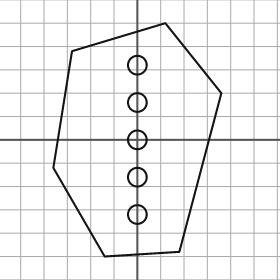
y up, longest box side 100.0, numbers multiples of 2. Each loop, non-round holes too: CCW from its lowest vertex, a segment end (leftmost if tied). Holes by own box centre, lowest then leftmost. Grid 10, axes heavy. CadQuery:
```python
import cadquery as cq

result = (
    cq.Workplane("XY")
    .moveTo(-14.0, -50.0)
    .lineTo(18.0, -48.0)
    .lineTo(36.0, 20.0)
    .lineTo(12.0, 50.0)
    .lineTo(-28.0, 38.0)
    .lineTo(-36.0, -12.0)
    .close()
    .moveTo(0.0, -32.0)
    .circle(4.0)
    .moveTo(0.0, -16.0)
    .circle(4.0)
    .moveTo(0.0, 0.0)
    .circle(4.0)
    .moveTo(0.0, 16.0)
    .circle(4.0)
    .moveTo(0.0, 32.0)
    .circle(4.0)
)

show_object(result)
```